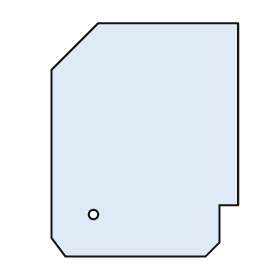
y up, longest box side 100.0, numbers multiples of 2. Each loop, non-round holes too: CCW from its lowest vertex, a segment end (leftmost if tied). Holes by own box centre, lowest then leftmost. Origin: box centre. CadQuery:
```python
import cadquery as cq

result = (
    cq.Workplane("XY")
    .moveTo(-34.0, -50.0)
    .lineTo(26.0, -50.0)
    .lineTo(32.0, -44.0)
    .lineTo(32.0, -28.0)
    .lineTo(40.0, -28.0)
    .lineTo(40.0, 50.0)
    .lineTo(-20.0, 50.0)
    .lineTo(-40.0, 30.0)
    .lineTo(-40.0, -42.0)
    .close()
    .moveTo(-22.0, -32.0)
    .circle(2.0)
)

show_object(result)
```